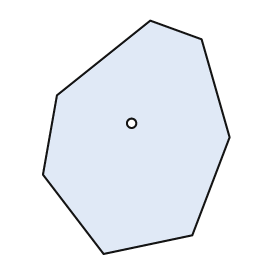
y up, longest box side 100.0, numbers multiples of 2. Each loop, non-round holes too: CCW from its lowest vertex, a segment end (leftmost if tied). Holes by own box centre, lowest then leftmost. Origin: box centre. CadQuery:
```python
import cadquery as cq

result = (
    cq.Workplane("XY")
    .moveTo(-14.0, -50.0)
    .lineTo(24.0, -42.0)
    .lineTo(40.0, 0.0)
    .lineTo(28.0, 42.0)
    .lineTo(6.0, 50.0)
    .lineTo(-34.0, 18.0)
    .lineTo(-40.0, -16.0)
    .close()
    .moveTo(-2.0, 6.0)
    .circle(2.0)
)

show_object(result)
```